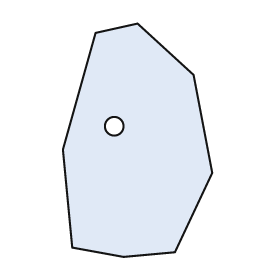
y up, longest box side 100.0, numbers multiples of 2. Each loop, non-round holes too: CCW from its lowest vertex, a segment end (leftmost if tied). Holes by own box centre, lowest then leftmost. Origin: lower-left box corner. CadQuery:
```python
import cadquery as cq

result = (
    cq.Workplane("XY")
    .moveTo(26.0, 0.0)
    .lineTo(48.0, 2.0)
    .lineTo(64.0, 36.0)
    .lineTo(56.0, 78.0)
    .lineTo(32.0, 100.0)
    .lineTo(14.0, 96.0)
    .lineTo(0.0, 46.0)
    .lineTo(4.0, 4.0)
    .close()
    .moveTo(22.0, 56.0)
    .circle(4.0)
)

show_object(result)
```